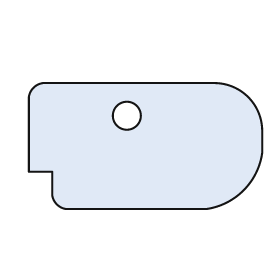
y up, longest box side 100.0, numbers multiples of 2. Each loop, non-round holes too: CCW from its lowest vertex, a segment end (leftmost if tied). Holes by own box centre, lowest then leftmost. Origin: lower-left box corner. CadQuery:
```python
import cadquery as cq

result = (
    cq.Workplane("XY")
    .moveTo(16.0, 0.0)
    .lineTo(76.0, 0.0)
    .threePointArc((92.0, 8.0), (100.0, 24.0))
    .lineTo(100.0, 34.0)
    .threePointArc((94.0, 48.0), (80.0, 54.0))
    .lineTo(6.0, 54.0)
    .threePointArc((2.0, 52.0), (0.0, 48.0))
    .lineTo(0.0, 16.0)
    .lineTo(10.0, 16.0)
    .lineTo(10.0, 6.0)
    .threePointArc((12.0, 2.0), (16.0, 0.0))
    .close()
    .moveTo(42.0, 40.0)
    .circle(6.0)
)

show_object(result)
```